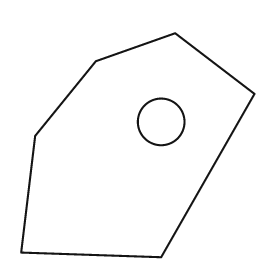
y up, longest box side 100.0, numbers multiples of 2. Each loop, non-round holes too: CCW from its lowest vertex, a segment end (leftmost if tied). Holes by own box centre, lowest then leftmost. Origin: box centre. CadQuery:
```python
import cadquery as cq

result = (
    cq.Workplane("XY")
    .moveTo(10.0, -48.0)
    .lineTo(50.0, 22.0)
    .lineTo(16.0, 48.0)
    .lineTo(-18.0, 36.0)
    .lineTo(-44.0, 4.0)
    .lineTo(-50.0, -46.0)
    .close()
    .moveTo(10.0, 10.0)
    .circle(10.0)
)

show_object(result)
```